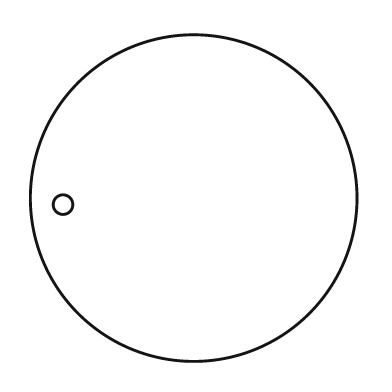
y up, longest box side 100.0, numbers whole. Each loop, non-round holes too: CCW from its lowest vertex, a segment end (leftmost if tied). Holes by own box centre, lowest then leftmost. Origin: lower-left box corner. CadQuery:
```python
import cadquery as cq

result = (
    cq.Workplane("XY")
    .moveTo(50.0, 50.0)
    .circle(50.0)
    .moveTo(10.0, 48.0)
    .circle(3.0)
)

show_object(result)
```